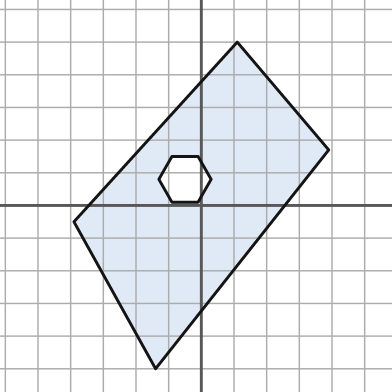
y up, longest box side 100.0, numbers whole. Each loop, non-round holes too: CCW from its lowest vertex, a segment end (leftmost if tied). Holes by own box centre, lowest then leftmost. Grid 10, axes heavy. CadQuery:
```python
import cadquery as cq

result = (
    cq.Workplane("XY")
    .moveTo(-14.0, -50.0)
    .lineTo(39.0, 17.0)
    .lineTo(11.0, 50.0)
    .lineTo(-39.0, -5.0)
    .close()
    .moveTo(-9.0, 1.0)
    .lineTo(-1.0, 1.0)
    .lineTo(3.0, 8.0)
    .lineTo(-1.0, 15.0)
    .lineTo(-9.0, 15.0)
    .lineTo(-13.0, 8.0)
    .close()
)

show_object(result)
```